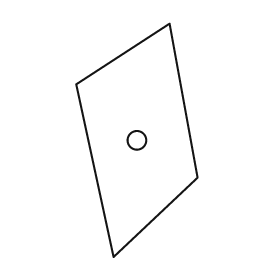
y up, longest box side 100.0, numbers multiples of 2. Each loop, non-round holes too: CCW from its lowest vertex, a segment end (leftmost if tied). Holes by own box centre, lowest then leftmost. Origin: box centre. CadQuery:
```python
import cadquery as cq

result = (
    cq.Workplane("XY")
    .moveTo(-10.0, -50.0)
    .lineTo(26.0, -16.0)
    .lineTo(14.0, 50.0)
    .lineTo(-26.0, 24.0)
    .close()
    .moveTo(0.0, 0.0)
    .circle(4.0)
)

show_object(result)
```